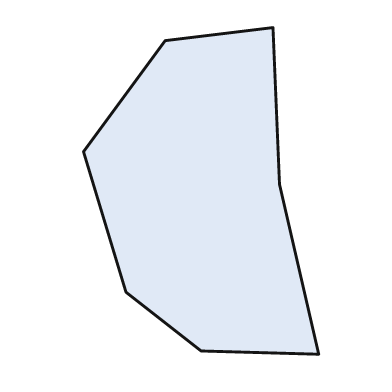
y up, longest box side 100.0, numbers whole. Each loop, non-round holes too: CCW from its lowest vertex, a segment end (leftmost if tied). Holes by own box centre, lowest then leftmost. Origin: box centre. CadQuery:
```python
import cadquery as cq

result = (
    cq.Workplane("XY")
    .moveTo(36.0, -50.0)
    .lineTo(24.0, 2.0)
    .lineTo(22.0, 50.0)
    .lineTo(-11.0, 46.0)
    .lineTo(-36.0, 12.0)
    .lineTo(-23.0, -31.0)
    .lineTo(0.0, -49.0)
    .close()
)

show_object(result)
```